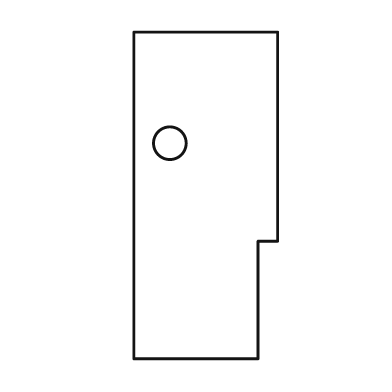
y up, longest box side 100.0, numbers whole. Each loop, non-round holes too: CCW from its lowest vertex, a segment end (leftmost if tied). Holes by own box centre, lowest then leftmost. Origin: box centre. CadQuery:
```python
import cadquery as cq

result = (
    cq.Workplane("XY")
    .moveTo(-22.0, -50.0)
    .lineTo(16.0, -50.0)
    .lineTo(16.0, -14.0)
    .lineTo(22.0, -14.0)
    .lineTo(22.0, 50.0)
    .lineTo(-22.0, 50.0)
    .close()
    .moveTo(-11.0, 16.0)
    .circle(5.0)
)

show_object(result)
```